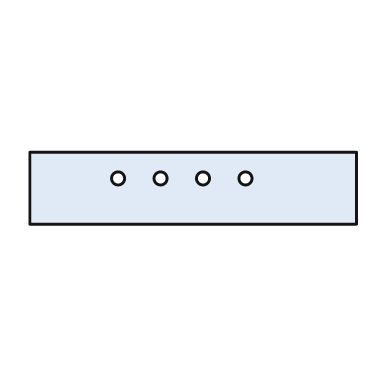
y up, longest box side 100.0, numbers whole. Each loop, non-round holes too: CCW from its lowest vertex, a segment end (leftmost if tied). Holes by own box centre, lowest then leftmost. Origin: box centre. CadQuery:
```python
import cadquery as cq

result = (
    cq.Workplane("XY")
    .moveTo(-50.0, -11.0)
    .lineTo(50.0, -11.0)
    .lineTo(50.0, 11.0)
    .lineTo(-50.0, 11.0)
    .close()
    .moveTo(-23.0, 3.0)
    .circle(2.0)
    .moveTo(-10.0, 3.0)
    .circle(2.0)
    .moveTo(3.0, 3.0)
    .circle(2.0)
    .moveTo(16.0, 3.0)
    .circle(2.0)
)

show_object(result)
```